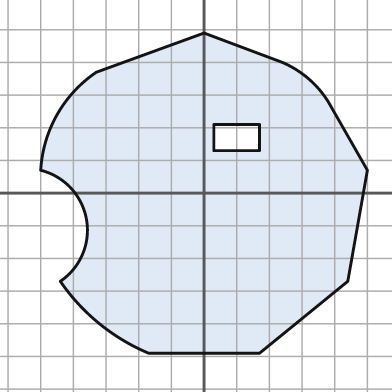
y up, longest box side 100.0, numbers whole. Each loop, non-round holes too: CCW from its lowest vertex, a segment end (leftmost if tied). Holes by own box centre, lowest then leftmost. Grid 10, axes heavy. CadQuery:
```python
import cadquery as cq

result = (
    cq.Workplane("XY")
    .moveTo(-17.0, -49.0)
    .lineTo(17.0, -49.0)
    .lineTo(44.0, -27.0)
    .lineTo(50.0, 7.0)
    .lineTo(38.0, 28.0)
    .threePointArc((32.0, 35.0), (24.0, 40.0))
    .lineTo(0.0, 49.0)
    .lineTo(-33.0, 37.0)
    .threePointArc((-45.0, 24.0), (-50.0, 7.0))
    .threePointArc((-36.0, -8.0), (-44.0, -27.0))
    .threePointArc((-32.0, -40.0), (-17.0, -49.0))
    .close()
    .moveTo(3.0, 13.0)
    .lineTo(17.0, 13.0)
    .lineTo(17.0, 21.0)
    .lineTo(3.0, 21.0)
    .close()
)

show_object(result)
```